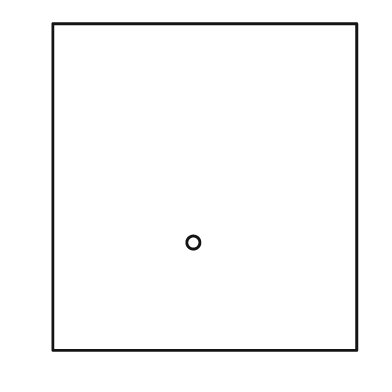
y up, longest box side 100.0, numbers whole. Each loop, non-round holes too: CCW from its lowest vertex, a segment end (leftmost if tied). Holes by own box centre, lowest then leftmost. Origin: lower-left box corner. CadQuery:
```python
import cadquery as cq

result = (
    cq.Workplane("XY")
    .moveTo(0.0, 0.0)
    .lineTo(93.0, 0.0)
    .lineTo(93.0, 100.0)
    .lineTo(0.0, 100.0)
    .close()
    .moveTo(43.0, 33.0)
    .circle(2.0)
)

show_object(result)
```